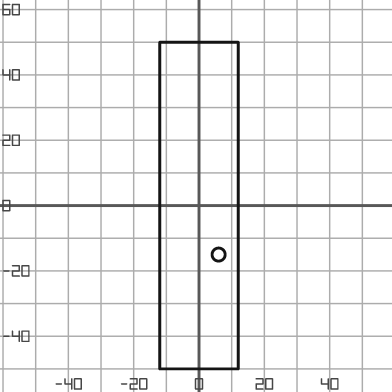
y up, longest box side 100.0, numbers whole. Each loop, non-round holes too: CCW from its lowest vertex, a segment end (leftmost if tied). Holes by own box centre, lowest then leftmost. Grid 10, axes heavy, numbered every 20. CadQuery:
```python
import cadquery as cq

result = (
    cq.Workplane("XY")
    .moveTo(-12.0, -50.0)
    .lineTo(12.0, -50.0)
    .lineTo(12.0, 50.0)
    .lineTo(-12.0, 50.0)
    .close()
    .moveTo(6.0, -15.0)
    .circle(2.0)
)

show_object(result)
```